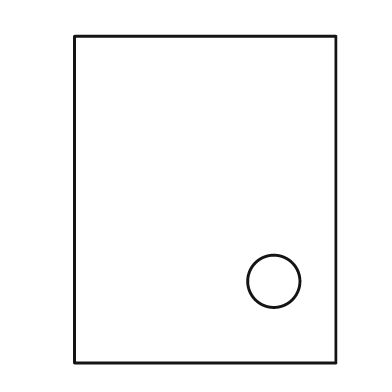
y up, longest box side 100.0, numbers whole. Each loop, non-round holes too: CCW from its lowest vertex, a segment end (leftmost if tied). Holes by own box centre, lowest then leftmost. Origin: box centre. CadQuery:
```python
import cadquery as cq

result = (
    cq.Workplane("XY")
    .moveTo(-40.0, -50.0)
    .lineTo(40.0, -50.0)
    .lineTo(40.0, 50.0)
    .lineTo(-40.0, 50.0)
    .close()
    .moveTo(21.0, -25.0)
    .circle(8.0)
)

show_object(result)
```